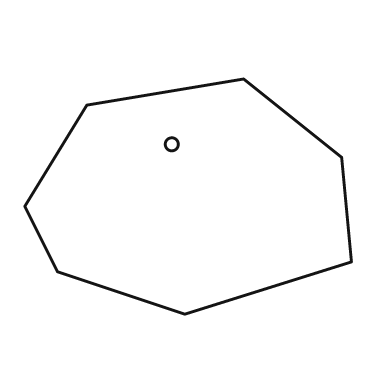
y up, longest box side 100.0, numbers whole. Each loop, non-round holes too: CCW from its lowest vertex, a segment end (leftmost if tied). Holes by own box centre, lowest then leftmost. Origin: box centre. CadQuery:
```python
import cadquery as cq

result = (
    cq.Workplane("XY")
    .moveTo(-1.0, -36.0)
    .lineTo(50.0, -20.0)
    .lineTo(47.0, 12.0)
    .lineTo(17.0, 36.0)
    .lineTo(-31.0, 28.0)
    .lineTo(-50.0, -3.0)
    .lineTo(-40.0, -23.0)
    .close()
    .moveTo(-5.0, 16.0)
    .circle(2.0)
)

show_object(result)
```